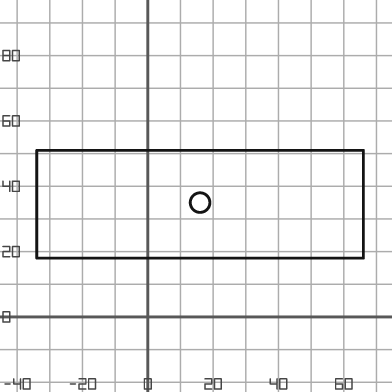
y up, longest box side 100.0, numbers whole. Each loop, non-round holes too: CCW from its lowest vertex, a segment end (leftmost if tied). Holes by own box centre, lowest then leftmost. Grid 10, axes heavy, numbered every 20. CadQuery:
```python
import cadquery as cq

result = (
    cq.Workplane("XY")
    .moveTo(-34.0, 18.0)
    .lineTo(66.0, 18.0)
    .lineTo(66.0, 51.0)
    .lineTo(-34.0, 51.0)
    .close()
    .moveTo(16.0, 35.0)
    .circle(3.0)
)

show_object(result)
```